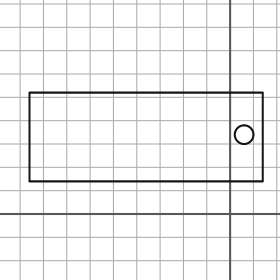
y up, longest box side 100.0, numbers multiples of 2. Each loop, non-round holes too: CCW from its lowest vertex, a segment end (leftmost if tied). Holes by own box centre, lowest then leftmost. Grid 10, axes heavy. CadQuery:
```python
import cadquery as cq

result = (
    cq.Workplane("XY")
    .moveTo(-86.0, 14.0)
    .lineTo(14.0, 14.0)
    .lineTo(14.0, 52.0)
    .lineTo(-86.0, 52.0)
    .close()
    .moveTo(6.0, 34.0)
    .circle(4.0)
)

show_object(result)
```